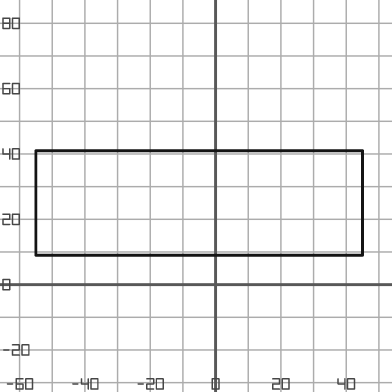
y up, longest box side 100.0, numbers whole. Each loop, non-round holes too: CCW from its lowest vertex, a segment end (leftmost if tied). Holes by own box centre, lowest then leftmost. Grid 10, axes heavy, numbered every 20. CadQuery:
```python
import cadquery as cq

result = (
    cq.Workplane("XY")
    .moveTo(-55.0, 9.0)
    .lineTo(45.0, 9.0)
    .lineTo(45.0, 41.0)
    .lineTo(-55.0, 41.0)
    .close()
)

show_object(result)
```